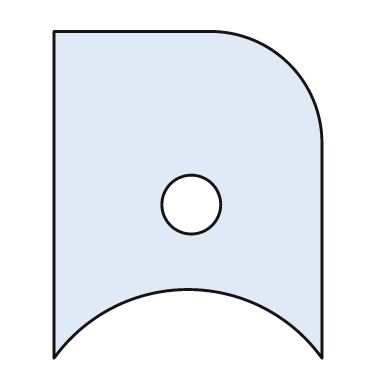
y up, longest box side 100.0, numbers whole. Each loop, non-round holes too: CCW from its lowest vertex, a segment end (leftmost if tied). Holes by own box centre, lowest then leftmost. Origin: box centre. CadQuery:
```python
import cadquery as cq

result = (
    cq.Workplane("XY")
    .moveTo(-41.0, -50.0)
    .threePointArc((0.0, -29.0), (41.0, -50.0))
    .lineTo(41.0, 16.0)
    .threePointArc((31.0, 40.0), (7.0, 50.0))
    .lineTo(-41.0, 50.0)
    .close()
    .moveTo(1.0, -3.0)
    .circle(9.0)
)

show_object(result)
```